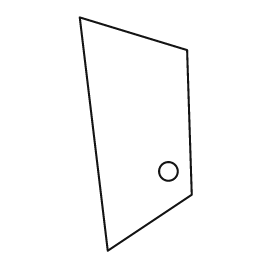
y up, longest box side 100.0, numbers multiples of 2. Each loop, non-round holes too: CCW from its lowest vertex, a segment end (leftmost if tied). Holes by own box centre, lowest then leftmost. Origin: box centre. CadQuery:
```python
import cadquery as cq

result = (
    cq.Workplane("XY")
    .moveTo(-12.0, -50.0)
    .lineTo(24.0, -26.0)
    .lineTo(22.0, 36.0)
    .lineTo(-24.0, 50.0)
    .close()
    .moveTo(14.0, -16.0)
    .circle(4.0)
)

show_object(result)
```